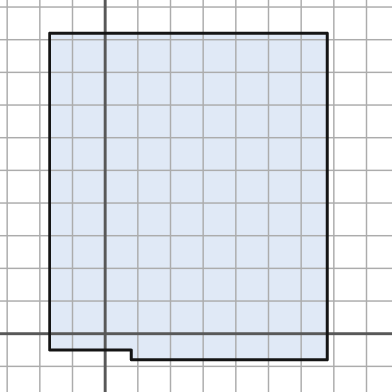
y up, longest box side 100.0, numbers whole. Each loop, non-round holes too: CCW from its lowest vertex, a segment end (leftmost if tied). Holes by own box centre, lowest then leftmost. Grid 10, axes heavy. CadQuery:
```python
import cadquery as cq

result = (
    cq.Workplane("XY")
    .moveTo(8.0, -8.0)
    .lineTo(68.0, -8.0)
    .lineTo(68.0, 92.0)
    .lineTo(-17.0, 92.0)
    .lineTo(-17.0, -5.0)
    .lineTo(8.0, -5.0)
    .close()
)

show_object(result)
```